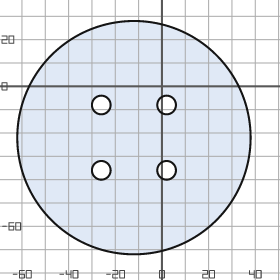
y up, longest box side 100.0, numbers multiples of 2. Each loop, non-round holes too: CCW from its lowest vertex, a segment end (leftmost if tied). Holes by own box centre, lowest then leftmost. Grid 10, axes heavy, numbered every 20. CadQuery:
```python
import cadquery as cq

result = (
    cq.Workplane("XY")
    .moveTo(-12.0, -22.0)
    .circle(50.0)
    .moveTo(-26.0, -36.0)
    .circle(4.0)
    .moveTo(2.0, -36.0)
    .circle(4.0)
    .moveTo(-26.0, -8.0)
    .circle(4.0)
    .moveTo(2.0, -8.0)
    .circle(4.0)
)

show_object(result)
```